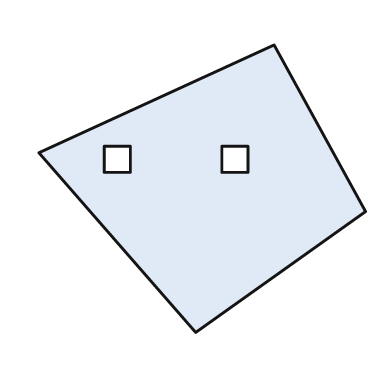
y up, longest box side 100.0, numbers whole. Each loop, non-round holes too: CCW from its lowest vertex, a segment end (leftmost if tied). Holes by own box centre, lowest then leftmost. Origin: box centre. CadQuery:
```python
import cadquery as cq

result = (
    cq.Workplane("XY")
    .moveTo(-2.0, -44.0)
    .lineTo(50.0, -7.0)
    .lineTo(22.0, 44.0)
    .lineTo(-50.0, 11.0)
    .close()
    .moveTo(-30.0, 5.0)
    .lineTo(-22.0, 5.0)
    .lineTo(-22.0, 13.0)
    .lineTo(-30.0, 13.0)
    .close()
    .moveTo(6.0, 5.0)
    .lineTo(14.0, 5.0)
    .lineTo(14.0, 13.0)
    .lineTo(6.0, 13.0)
    .close()
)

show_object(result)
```